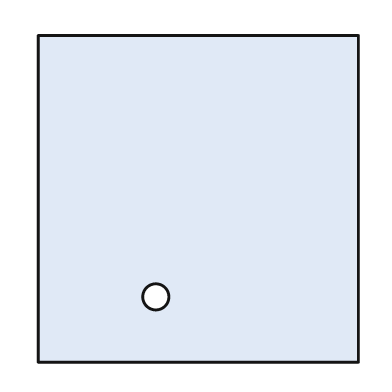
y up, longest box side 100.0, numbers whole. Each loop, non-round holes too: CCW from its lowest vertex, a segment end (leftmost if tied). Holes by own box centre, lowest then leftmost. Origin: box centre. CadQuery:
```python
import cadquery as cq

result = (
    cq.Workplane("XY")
    .moveTo(-49.0, -50.0)
    .lineTo(49.0, -50.0)
    .lineTo(49.0, 50.0)
    .lineTo(-49.0, 50.0)
    .close()
    .moveTo(-13.0, -30.0)
    .circle(4.0)
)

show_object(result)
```